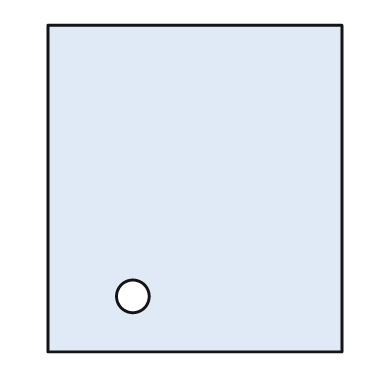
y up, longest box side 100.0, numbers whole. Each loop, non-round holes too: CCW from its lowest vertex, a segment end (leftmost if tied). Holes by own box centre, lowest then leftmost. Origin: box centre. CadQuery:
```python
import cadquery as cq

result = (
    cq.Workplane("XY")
    .moveTo(-45.0, -50.0)
    .lineTo(45.0, -50.0)
    .lineTo(45.0, 50.0)
    .lineTo(-45.0, 50.0)
    .close()
    .moveTo(-19.0, -33.0)
    .circle(5.0)
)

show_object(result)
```